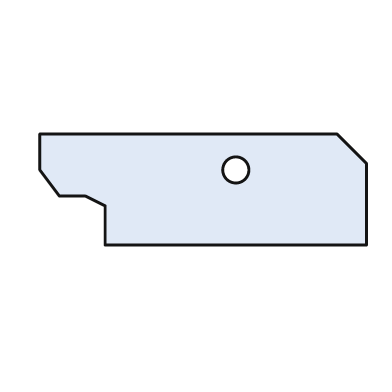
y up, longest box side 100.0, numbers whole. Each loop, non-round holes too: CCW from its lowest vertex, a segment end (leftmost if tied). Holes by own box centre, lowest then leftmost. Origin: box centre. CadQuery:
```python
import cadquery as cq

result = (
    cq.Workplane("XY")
    .moveTo(-30.0, -17.0)
    .lineTo(50.0, -17.0)
    .lineTo(50.0, 8.0)
    .lineTo(41.0, 17.0)
    .lineTo(-50.0, 17.0)
    .lineTo(-50.0, 6.0)
    .lineTo(-44.0, -2.0)
    .lineTo(-36.0, -2.0)
    .lineTo(-30.0, -5.0)
    .close()
    .moveTo(10.0, 6.0)
    .circle(4.0)
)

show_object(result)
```